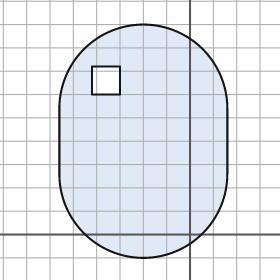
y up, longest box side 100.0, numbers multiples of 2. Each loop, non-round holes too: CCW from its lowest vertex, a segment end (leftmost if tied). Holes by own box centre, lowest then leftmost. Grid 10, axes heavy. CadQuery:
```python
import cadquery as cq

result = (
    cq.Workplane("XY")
    .moveTo(-56.0, 26.0)
    .threePointArc((-20.0, -10.0), (16.0, 26.0))
    .lineTo(16.0, 54.0)
    .threePointArc((-20.0, 90.0), (-56.0, 54.0))
    .close()
    .moveTo(-42.0, 60.0)
    .lineTo(-30.0, 60.0)
    .lineTo(-30.0, 72.0)
    .lineTo(-42.0, 72.0)
    .close()
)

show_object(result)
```